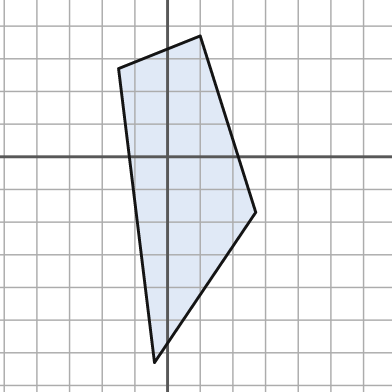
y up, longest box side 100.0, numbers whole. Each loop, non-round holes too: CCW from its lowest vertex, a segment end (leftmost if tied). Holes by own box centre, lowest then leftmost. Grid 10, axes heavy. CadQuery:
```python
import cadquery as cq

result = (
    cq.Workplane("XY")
    .moveTo(-4.0, -63.0)
    .lineTo(27.0, -17.0)
    .lineTo(10.0, 37.0)
    .lineTo(-15.0, 27.0)
    .close()
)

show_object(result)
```